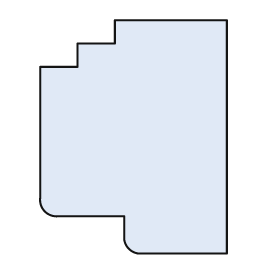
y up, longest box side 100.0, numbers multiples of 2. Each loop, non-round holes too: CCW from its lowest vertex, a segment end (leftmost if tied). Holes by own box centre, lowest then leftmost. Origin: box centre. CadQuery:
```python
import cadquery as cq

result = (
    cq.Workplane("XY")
    .moveTo(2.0, -50.0)
    .lineTo(40.0, -50.0)
    .lineTo(40.0, 50.0)
    .lineTo(-8.0, 50.0)
    .lineTo(-8.0, 40.0)
    .lineTo(-24.0, 40.0)
    .lineTo(-24.0, 30.0)
    .lineTo(-40.0, 30.0)
    .lineTo(-40.0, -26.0)
    .threePointArc((-38.0, -32.0), (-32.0, -34.0))
    .lineTo(-4.0, -34.0)
    .lineTo(-4.0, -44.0)
    .threePointArc((-2.0, -48.0), (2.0, -50.0))
    .close()
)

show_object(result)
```